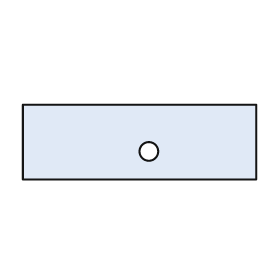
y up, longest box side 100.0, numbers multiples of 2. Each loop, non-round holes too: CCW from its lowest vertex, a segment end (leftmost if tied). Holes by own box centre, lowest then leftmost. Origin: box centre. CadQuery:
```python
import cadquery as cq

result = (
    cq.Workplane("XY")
    .moveTo(-50.0, -16.0)
    .lineTo(50.0, -16.0)
    .lineTo(50.0, 16.0)
    .lineTo(-50.0, 16.0)
    .close()
    .moveTo(4.0, -4.0)
    .circle(4.0)
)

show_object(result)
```